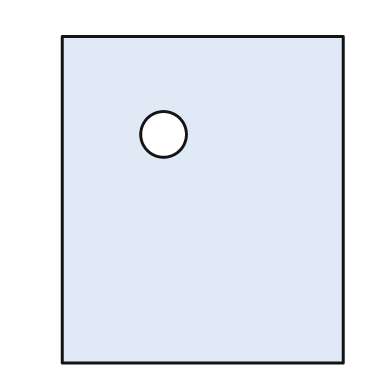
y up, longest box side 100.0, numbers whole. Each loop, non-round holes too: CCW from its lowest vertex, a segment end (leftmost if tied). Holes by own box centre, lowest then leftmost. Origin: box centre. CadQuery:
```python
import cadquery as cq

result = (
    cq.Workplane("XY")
    .moveTo(-43.0, -50.0)
    .lineTo(43.0, -50.0)
    .lineTo(43.0, 50.0)
    .lineTo(-43.0, 50.0)
    .close()
    .moveTo(-12.0, 20.0)
    .circle(7.0)
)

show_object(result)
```